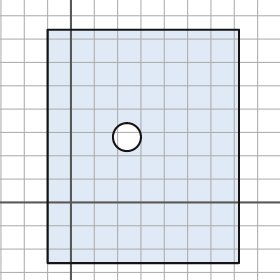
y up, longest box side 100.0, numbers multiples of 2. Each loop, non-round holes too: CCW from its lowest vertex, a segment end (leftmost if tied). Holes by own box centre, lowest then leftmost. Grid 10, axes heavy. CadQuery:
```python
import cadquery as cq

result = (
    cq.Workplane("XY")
    .moveTo(-10.0, -26.0)
    .lineTo(72.0, -26.0)
    .lineTo(72.0, 74.0)
    .lineTo(-10.0, 74.0)
    .close()
    .moveTo(24.0, 28.0)
    .circle(6.0)
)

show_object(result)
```